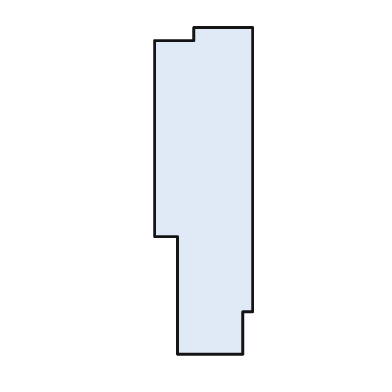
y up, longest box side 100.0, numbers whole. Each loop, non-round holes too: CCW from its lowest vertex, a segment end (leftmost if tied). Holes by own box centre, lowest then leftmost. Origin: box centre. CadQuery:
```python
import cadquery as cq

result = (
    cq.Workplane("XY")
    .moveTo(-8.0, -50.0)
    .lineTo(12.0, -50.0)
    .lineTo(12.0, -37.0)
    .lineTo(15.0, -37.0)
    .lineTo(15.0, 50.0)
    .lineTo(-3.0, 50.0)
    .lineTo(-3.0, 46.0)
    .lineTo(-15.0, 46.0)
    .lineTo(-15.0, -14.0)
    .lineTo(-8.0, -14.0)
    .close()
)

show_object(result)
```